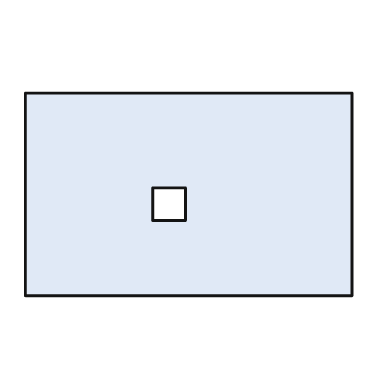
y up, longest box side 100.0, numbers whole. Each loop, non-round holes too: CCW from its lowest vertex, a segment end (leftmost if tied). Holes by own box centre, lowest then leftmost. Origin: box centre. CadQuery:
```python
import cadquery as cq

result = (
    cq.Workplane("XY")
    .moveTo(-50.0, -31.0)
    .lineTo(50.0, -31.0)
    .lineTo(50.0, 31.0)
    .lineTo(-50.0, 31.0)
    .close()
    .moveTo(-11.0, -8.0)
    .lineTo(-1.0, -8.0)
    .lineTo(-1.0, 2.0)
    .lineTo(-11.0, 2.0)
    .close()
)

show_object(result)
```